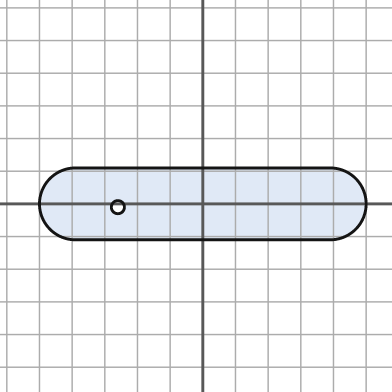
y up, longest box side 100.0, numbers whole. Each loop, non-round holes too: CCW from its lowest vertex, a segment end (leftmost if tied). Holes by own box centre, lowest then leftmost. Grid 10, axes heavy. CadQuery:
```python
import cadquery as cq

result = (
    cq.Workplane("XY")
    .moveTo(-39.0, -11.0)
    .lineTo(39.0, -11.0)
    .threePointArc((50.0, 0.0), (39.0, 11.0))
    .lineTo(-39.0, 11.0)
    .threePointArc((-50.0, 0.0), (-39.0, -11.0))
    .close()
    .moveTo(-26.0, -1.0)
    .circle(2.0)
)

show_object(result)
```